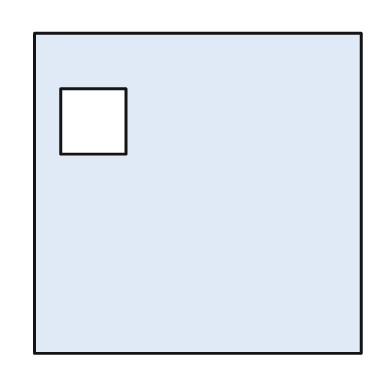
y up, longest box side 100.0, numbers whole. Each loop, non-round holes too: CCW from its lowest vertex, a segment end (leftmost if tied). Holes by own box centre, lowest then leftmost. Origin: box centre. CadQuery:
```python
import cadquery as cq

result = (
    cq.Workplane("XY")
    .moveTo(-50.0, -49.0)
    .lineTo(50.0, -49.0)
    .lineTo(50.0, 49.0)
    .lineTo(-50.0, 49.0)
    .close()
    .moveTo(-42.0, 12.0)
    .lineTo(-22.0, 12.0)
    .lineTo(-22.0, 32.0)
    .lineTo(-42.0, 32.0)
    .close()
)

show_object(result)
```